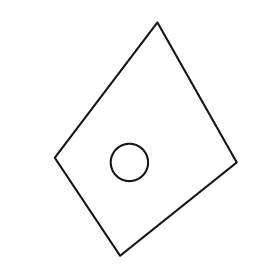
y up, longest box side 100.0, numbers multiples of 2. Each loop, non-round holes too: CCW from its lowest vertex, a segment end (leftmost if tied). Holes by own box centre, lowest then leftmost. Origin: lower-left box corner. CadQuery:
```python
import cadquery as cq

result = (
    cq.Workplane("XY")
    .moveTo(28.0, 0.0)
    .lineTo(78.0, 40.0)
    .lineTo(44.0, 100.0)
    .lineTo(0.0, 42.0)
    .close()
    .moveTo(32.0, 40.0)
    .circle(8.0)
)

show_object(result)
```